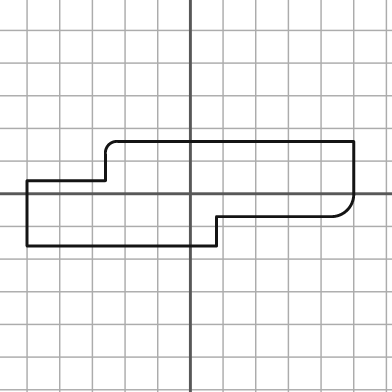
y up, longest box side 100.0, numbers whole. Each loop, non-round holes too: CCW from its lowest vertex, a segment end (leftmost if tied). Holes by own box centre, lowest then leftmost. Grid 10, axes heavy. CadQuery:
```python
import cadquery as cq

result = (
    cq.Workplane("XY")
    .moveTo(-50.0, -16.0)
    .lineTo(8.0, -16.0)
    .lineTo(8.0, -7.0)
    .lineTo(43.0, -7.0)
    .threePointArc((48.0, -5.0), (50.0, 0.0))
    .lineTo(50.0, 16.0)
    .lineTo(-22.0, 16.0)
    .threePointArc((-25.0, 15.0), (-26.0, 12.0))
    .lineTo(-26.0, 4.0)
    .lineTo(-50.0, 4.0)
    .close()
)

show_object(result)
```